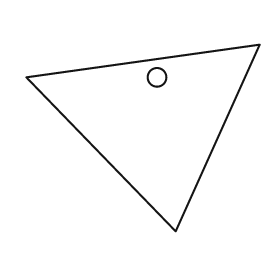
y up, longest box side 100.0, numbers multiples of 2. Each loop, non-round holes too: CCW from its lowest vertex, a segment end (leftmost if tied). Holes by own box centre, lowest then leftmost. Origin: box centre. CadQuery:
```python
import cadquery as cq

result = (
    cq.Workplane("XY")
    .moveTo(14.0, -40.0)
    .lineTo(50.0, 40.0)
    .lineTo(-50.0, 26.0)
    .close()
    .moveTo(6.0, 26.0)
    .circle(4.0)
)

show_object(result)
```